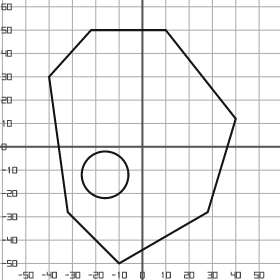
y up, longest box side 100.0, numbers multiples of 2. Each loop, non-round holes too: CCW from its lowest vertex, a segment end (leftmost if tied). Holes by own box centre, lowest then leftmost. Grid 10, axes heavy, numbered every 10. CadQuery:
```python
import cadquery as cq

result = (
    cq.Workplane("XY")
    .moveTo(-10.0, -50.0)
    .lineTo(28.0, -28.0)
    .lineTo(40.0, 12.0)
    .lineTo(10.0, 50.0)
    .lineTo(-22.0, 50.0)
    .lineTo(-40.0, 30.0)
    .lineTo(-32.0, -28.0)
    .close()
    .moveTo(-16.0, -12.0)
    .circle(10.0)
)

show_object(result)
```